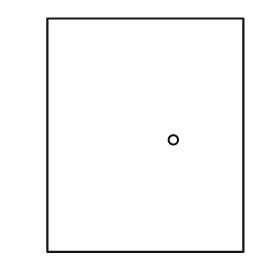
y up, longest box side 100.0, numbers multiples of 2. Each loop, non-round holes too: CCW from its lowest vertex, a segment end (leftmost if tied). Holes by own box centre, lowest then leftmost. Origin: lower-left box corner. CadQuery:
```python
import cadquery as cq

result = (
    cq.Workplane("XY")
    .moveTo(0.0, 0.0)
    .lineTo(84.0, 0.0)
    .lineTo(84.0, 100.0)
    .lineTo(0.0, 100.0)
    .close()
    .moveTo(54.0, 48.0)
    .circle(2.0)
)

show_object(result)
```